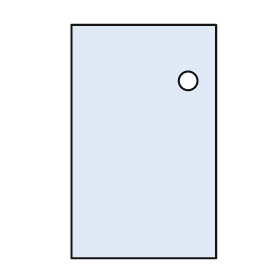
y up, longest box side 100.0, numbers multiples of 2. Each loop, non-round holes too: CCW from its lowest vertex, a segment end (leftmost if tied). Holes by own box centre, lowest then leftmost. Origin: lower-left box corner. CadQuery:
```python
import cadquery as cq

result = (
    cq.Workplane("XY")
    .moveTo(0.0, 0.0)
    .lineTo(62.0, 0.0)
    .lineTo(62.0, 100.0)
    .lineTo(0.0, 100.0)
    .close()
    .moveTo(50.0, 76.0)
    .circle(4.0)
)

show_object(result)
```